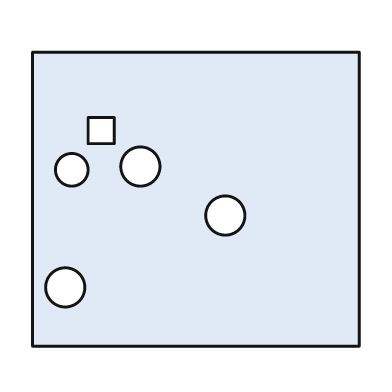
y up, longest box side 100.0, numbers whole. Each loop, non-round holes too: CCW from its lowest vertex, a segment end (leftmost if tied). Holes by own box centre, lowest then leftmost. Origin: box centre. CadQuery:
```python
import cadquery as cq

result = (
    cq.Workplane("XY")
    .moveTo(-50.0, -45.0)
    .lineTo(50.0, -45.0)
    .lineTo(50.0, 45.0)
    .lineTo(-50.0, 45.0)
    .close()
    .moveTo(-40.0, -27.0)
    .circle(6.0)
    .moveTo(9.0, -5.0)
    .circle(6.0)
    .moveTo(-38.0, 9.0)
    .circle(5.0)
    .moveTo(-17.0, 10.0)
    .circle(6.0)
    .moveTo(-33.0, 17.0)
    .lineTo(-25.0, 17.0)
    .lineTo(-25.0, 25.0)
    .lineTo(-33.0, 25.0)
    .close()
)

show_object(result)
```